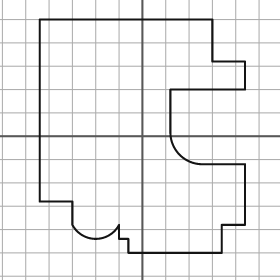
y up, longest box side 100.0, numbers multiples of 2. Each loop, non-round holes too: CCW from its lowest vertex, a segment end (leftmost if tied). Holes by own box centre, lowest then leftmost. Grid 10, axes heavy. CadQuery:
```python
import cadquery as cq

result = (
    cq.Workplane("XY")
    .moveTo(-6.0, -50.0)
    .lineTo(34.0, -50.0)
    .lineTo(34.0, -38.0)
    .lineTo(44.0, -38.0)
    .lineTo(44.0, -12.0)
    .lineTo(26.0, -12.0)
    .threePointArc((16.0, -8.0), (12.0, 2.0))
    .lineTo(12.0, 20.0)
    .lineTo(44.0, 20.0)
    .lineTo(44.0, 32.0)
    .lineTo(30.0, 32.0)
    .lineTo(30.0, 50.0)
    .lineTo(-44.0, 50.0)
    .lineTo(-44.0, -28.0)
    .lineTo(-30.0, -28.0)
    .lineTo(-30.0, -38.0)
    .threePointArc((-20.0, -44.0), (-10.0, -38.0))
    .lineTo(-10.0, -44.0)
    .lineTo(-6.0, -44.0)
    .close()
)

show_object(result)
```